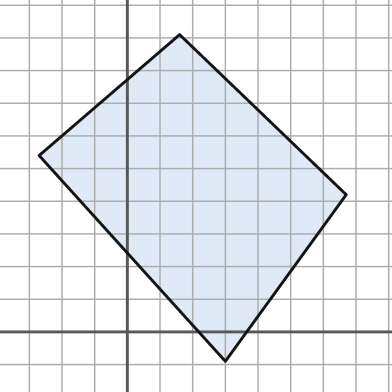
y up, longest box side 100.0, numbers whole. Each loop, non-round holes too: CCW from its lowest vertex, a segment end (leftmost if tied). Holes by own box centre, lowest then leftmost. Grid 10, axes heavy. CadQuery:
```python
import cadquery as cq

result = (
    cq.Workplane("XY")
    .moveTo(30.0, -9.0)
    .lineTo(67.0, 42.0)
    .lineTo(16.0, 91.0)
    .lineTo(-27.0, 54.0)
    .close()
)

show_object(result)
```